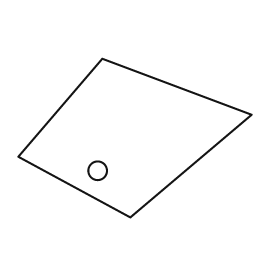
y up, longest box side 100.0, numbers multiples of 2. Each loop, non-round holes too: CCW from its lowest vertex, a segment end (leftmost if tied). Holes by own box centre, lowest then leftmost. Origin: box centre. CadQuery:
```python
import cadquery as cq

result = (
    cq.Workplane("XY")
    .moveTo(-2.0, -34.0)
    .lineTo(50.0, 10.0)
    .lineTo(-14.0, 34.0)
    .lineTo(-50.0, -8.0)
    .close()
    .moveTo(-16.0, -14.0)
    .circle(4.0)
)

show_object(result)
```